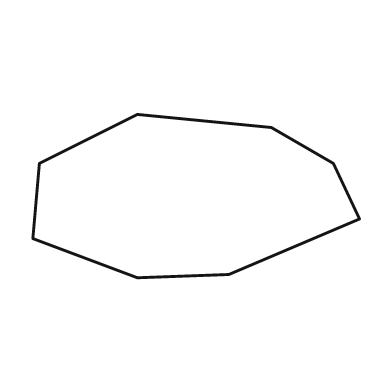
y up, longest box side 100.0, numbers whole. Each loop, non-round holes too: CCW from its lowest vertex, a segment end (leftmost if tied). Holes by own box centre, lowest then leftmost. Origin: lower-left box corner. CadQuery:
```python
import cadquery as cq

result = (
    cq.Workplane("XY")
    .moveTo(32.0, 0.0)
    .lineTo(60.0, 1.0)
    .lineTo(100.0, 18.0)
    .lineTo(92.0, 35.0)
    .lineTo(73.0, 46.0)
    .lineTo(32.0, 50.0)
    .lineTo(2.0, 35.0)
    .lineTo(0.0, 12.0)
    .close()
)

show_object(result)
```